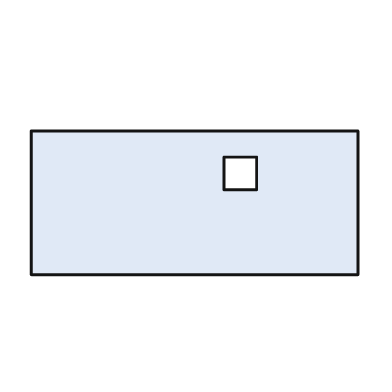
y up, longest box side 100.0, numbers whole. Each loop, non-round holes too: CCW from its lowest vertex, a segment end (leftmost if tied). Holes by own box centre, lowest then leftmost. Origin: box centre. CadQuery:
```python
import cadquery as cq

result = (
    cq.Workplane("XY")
    .moveTo(-50.0, -22.0)
    .lineTo(50.0, -22.0)
    .lineTo(50.0, 22.0)
    .lineTo(-50.0, 22.0)
    .close()
    .moveTo(9.0, 4.0)
    .lineTo(19.0, 4.0)
    .lineTo(19.0, 14.0)
    .lineTo(9.0, 14.0)
    .close()
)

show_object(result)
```